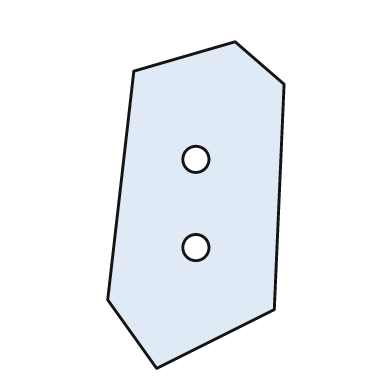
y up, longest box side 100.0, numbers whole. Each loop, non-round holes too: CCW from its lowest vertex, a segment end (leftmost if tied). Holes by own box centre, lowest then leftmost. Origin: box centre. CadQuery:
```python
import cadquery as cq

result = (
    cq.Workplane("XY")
    .moveTo(-12.0, -50.0)
    .lineTo(24.0, -32.0)
    .lineTo(27.0, 37.0)
    .lineTo(12.0, 50.0)
    .lineTo(-19.0, 41.0)
    .lineTo(-27.0, -29.0)
    .close()
    .moveTo(0.0, -13.0)
    .circle(4.0)
    .moveTo(0.0, 14.0)
    .circle(4.0)
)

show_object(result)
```